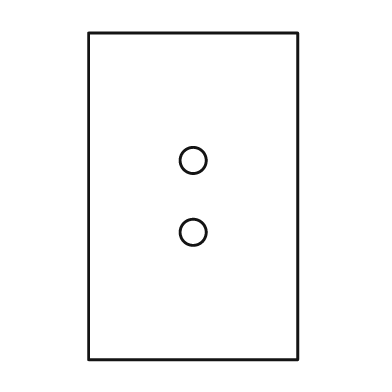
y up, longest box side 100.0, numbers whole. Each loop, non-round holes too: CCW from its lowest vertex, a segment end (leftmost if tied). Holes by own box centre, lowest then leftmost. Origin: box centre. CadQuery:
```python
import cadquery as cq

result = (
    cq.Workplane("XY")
    .moveTo(-32.0, -50.0)
    .lineTo(32.0, -50.0)
    .lineTo(32.0, 50.0)
    .lineTo(-32.0, 50.0)
    .close()
    .moveTo(0.0, -11.0)
    .circle(4.0)
    .moveTo(0.0, 11.0)
    .circle(4.0)
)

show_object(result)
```